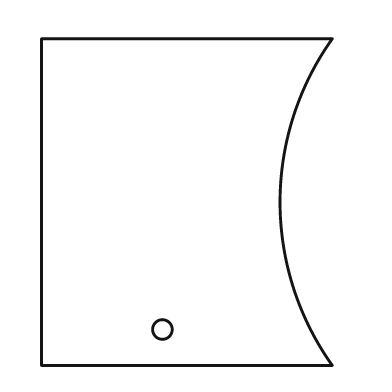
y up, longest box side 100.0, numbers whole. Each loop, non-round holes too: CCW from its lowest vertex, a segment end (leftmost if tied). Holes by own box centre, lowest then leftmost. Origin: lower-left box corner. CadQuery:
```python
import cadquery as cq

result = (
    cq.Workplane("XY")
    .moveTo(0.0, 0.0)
    .lineTo(89.0, 0.0)
    .threePointArc((73.0, 50.0), (89.0, 100.0))
    .lineTo(0.0, 100.0)
    .close()
    .moveTo(37.0, 11.0)
    .circle(3.0)
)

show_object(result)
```